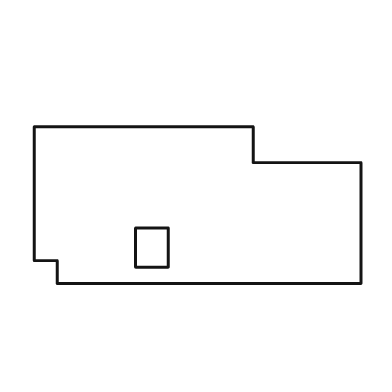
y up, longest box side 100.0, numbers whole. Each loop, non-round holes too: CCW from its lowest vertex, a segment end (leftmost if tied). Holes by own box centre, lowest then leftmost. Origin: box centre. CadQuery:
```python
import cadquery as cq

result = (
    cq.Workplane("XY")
    .moveTo(-43.0, -24.0)
    .lineTo(50.0, -24.0)
    .lineTo(50.0, 13.0)
    .lineTo(17.0, 13.0)
    .lineTo(17.0, 24.0)
    .lineTo(-50.0, 24.0)
    .lineTo(-50.0, -17.0)
    .lineTo(-43.0, -17.0)
    .close()
    .moveTo(-19.0, -19.0)
    .lineTo(-9.0, -19.0)
    .lineTo(-9.0, -7.0)
    .lineTo(-19.0, -7.0)
    .close()
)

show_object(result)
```